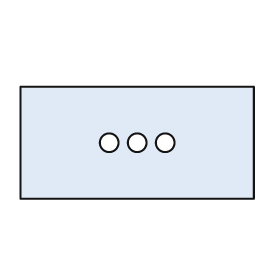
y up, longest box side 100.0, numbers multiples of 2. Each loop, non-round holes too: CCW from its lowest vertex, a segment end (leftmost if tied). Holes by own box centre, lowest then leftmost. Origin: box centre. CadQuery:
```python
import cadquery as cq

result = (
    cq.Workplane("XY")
    .moveTo(-50.0, -24.0)
    .lineTo(50.0, -24.0)
    .lineTo(50.0, 24.0)
    .lineTo(-50.0, 24.0)
    .close()
    .moveTo(-12.0, 0.0)
    .circle(4.0)
    .moveTo(0.0, 0.0)
    .circle(4.0)
    .moveTo(12.0, 0.0)
    .circle(4.0)
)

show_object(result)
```